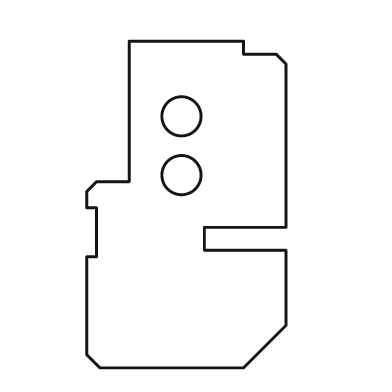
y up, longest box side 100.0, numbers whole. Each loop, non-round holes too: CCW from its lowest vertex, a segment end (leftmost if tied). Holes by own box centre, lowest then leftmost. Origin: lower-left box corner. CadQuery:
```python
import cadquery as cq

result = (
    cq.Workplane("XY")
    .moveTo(4.0, 0.0)
    .lineTo(48.0, 0.0)
    .lineTo(61.0, 13.0)
    .lineTo(61.0, 36.0)
    .lineTo(36.0, 36.0)
    .lineTo(36.0, 43.0)
    .lineTo(61.0, 43.0)
    .lineTo(61.0, 93.0)
    .lineTo(58.0, 96.0)
    .lineTo(48.0, 96.0)
    .lineTo(48.0, 100.0)
    .lineTo(13.0, 100.0)
    .lineTo(13.0, 57.0)
    .lineTo(3.0, 57.0)
    .lineTo(0.0, 54.0)
    .lineTo(0.0, 49.0)
    .lineTo(3.0, 49.0)
    .lineTo(3.0, 34.0)
    .lineTo(0.0, 34.0)
    .lineTo(0.0, 4.0)
    .close()
    .moveTo(29.0, 59.0)
    .circle(6.0)
    .moveTo(29.0, 77.0)
    .circle(6.0)
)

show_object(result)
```